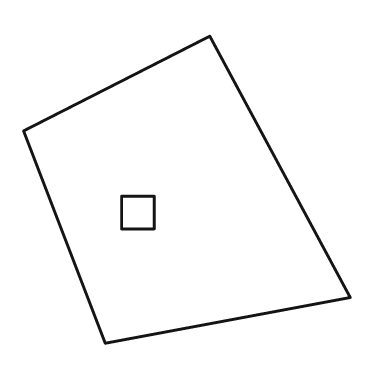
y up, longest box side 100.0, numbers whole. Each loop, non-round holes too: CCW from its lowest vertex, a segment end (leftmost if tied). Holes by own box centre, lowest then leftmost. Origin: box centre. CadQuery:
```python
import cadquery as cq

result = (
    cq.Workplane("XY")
    .moveTo(-25.0, -47.0)
    .lineTo(50.0, -33.0)
    .lineTo(7.0, 47.0)
    .lineTo(-50.0, 18.0)
    .close()
    .moveTo(-20.0, -12.0)
    .lineTo(-10.0, -12.0)
    .lineTo(-10.0, -2.0)
    .lineTo(-20.0, -2.0)
    .close()
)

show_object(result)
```